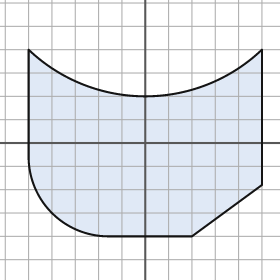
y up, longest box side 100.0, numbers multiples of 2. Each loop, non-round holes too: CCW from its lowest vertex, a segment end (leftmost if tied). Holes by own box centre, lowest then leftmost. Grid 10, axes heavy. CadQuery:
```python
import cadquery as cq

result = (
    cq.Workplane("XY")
    .moveTo(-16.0, -40.0)
    .lineTo(20.0, -40.0)
    .lineTo(50.0, -18.0)
    .lineTo(50.0, 40.0)
    .threePointArc((0.0, 20.0), (-50.0, 40.0))
    .lineTo(-50.0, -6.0)
    .threePointArc((-40.0, -30.0), (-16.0, -40.0))
    .close()
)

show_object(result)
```